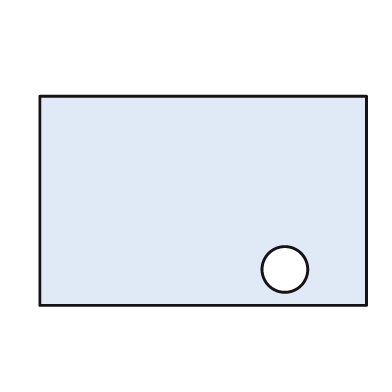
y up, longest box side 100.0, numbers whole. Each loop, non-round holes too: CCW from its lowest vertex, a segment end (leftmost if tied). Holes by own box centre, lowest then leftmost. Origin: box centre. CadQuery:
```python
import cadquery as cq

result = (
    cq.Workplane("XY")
    .moveTo(-50.0, -32.0)
    .lineTo(50.0, -32.0)
    .lineTo(50.0, 32.0)
    .lineTo(-50.0, 32.0)
    .close()
    .moveTo(25.0, -21.0)
    .circle(7.0)
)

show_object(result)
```